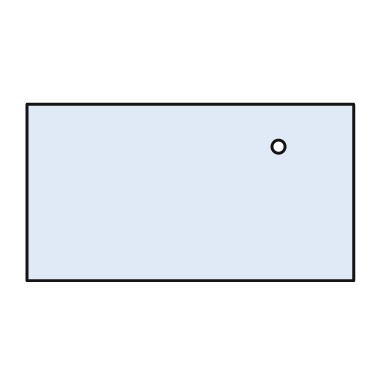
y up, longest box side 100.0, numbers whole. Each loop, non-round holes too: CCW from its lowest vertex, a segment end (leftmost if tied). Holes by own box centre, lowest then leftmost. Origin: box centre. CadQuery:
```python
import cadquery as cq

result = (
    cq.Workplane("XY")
    .moveTo(-50.0, -27.0)
    .lineTo(50.0, -27.0)
    .lineTo(50.0, 27.0)
    .lineTo(-50.0, 27.0)
    .close()
    .moveTo(27.0, 14.0)
    .circle(2.0)
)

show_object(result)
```